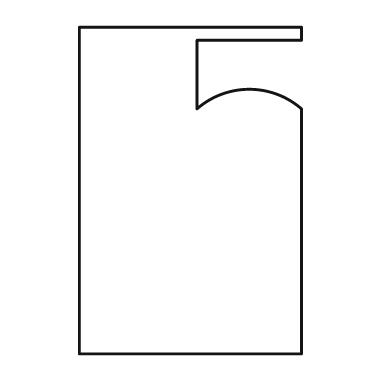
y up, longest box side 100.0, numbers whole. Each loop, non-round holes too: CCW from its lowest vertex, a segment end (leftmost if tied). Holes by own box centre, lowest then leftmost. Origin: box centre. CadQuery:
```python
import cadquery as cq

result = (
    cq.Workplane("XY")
    .moveTo(-34.0, -50.0)
    .lineTo(34.0, -50.0)
    .lineTo(34.0, 25.0)
    .threePointArc((18.0, 31.0), (2.0, 25.0))
    .lineTo(2.0, 46.0)
    .lineTo(34.0, 46.0)
    .lineTo(34.0, 50.0)
    .lineTo(-34.0, 50.0)
    .close()
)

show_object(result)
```